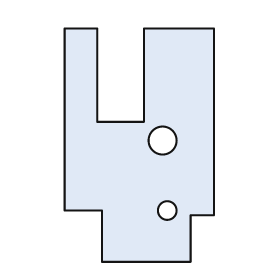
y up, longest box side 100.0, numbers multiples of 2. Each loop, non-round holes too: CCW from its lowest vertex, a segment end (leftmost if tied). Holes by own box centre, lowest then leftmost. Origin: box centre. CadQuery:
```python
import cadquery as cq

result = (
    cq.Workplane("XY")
    .moveTo(-16.0, -50.0)
    .lineTo(22.0, -50.0)
    .lineTo(22.0, -30.0)
    .lineTo(32.0, -30.0)
    .lineTo(32.0, 50.0)
    .lineTo(2.0, 50.0)
    .lineTo(2.0, 10.0)
    .lineTo(-18.0, 10.0)
    .lineTo(-18.0, 50.0)
    .lineTo(-32.0, 50.0)
    .lineTo(-32.0, -28.0)
    .lineTo(-16.0, -28.0)
    .close()
    .moveTo(12.0, -28.0)
    .circle(4.0)
    .moveTo(10.0, 2.0)
    .circle(6.0)
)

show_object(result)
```